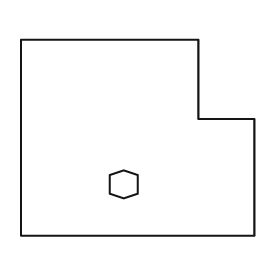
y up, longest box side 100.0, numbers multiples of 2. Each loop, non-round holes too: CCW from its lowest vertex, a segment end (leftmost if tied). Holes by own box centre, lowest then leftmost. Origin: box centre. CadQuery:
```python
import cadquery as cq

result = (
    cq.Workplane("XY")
    .moveTo(-50.0, -42.0)
    .lineTo(50.0, -42.0)
    .lineTo(50.0, 8.0)
    .lineTo(26.0, 8.0)
    .lineTo(26.0, 42.0)
    .lineTo(-50.0, 42.0)
    .close()
    .moveTo(-6.0, -26.0)
    .lineTo(0.0, -24.0)
    .lineTo(0.0, -16.0)
    .lineTo(-6.0, -14.0)
    .lineTo(-12.0, -16.0)
    .lineTo(-12.0, -24.0)
    .close()
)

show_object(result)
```